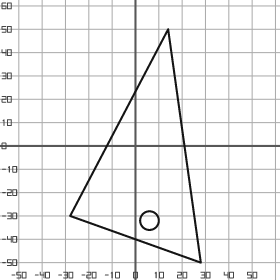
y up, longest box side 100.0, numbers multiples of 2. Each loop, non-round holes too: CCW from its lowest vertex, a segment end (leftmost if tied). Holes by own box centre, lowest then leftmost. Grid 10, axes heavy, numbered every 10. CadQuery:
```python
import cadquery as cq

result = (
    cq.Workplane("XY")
    .moveTo(28.0, -50.0)
    .lineTo(14.0, 50.0)
    .lineTo(-28.0, -30.0)
    .close()
    .moveTo(6.0, -32.0)
    .circle(4.0)
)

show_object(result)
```